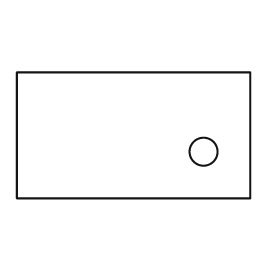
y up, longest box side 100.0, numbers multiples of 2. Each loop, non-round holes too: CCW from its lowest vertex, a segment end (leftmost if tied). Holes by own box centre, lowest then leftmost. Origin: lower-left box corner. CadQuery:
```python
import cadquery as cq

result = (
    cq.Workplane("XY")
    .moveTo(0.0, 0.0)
    .lineTo(100.0, 0.0)
    .lineTo(100.0, 54.0)
    .lineTo(0.0, 54.0)
    .close()
    .moveTo(80.0, 20.0)
    .circle(6.0)
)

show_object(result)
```